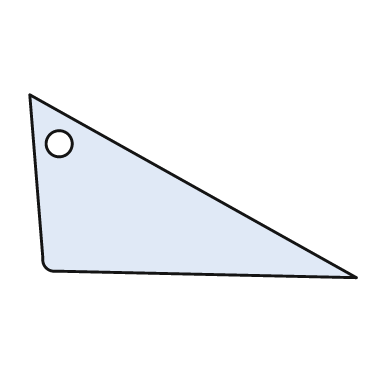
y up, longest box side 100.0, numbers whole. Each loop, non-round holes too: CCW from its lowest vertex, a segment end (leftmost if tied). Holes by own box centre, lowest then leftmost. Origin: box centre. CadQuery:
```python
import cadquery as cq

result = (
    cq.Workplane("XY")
    .moveTo(50.0, -28.0)
    .lineTo(-50.0, 28.0)
    .lineTo(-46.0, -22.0)
    .threePointArc((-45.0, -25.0), (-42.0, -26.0))
    .close()
    .moveTo(-41.0, 13.0)
    .circle(4.0)
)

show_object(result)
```